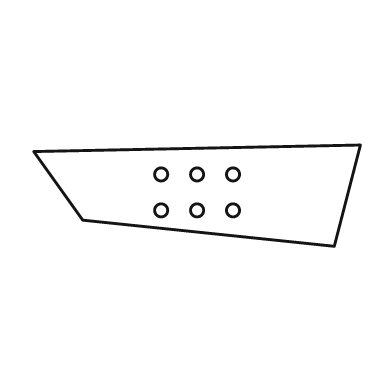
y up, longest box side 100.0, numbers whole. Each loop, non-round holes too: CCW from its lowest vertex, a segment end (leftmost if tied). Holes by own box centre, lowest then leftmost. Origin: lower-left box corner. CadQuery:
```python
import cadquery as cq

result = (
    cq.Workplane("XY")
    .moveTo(92.0, 0.0)
    .lineTo(100.0, 31.0)
    .lineTo(0.0, 29.0)
    .lineTo(15.0, 8.0)
    .close()
    .moveTo(39.0, 11.0)
    .circle(2.0)
    .moveTo(50.0, 11.0)
    .circle(2.0)
    .moveTo(61.0, 11.0)
    .circle(2.0)
    .moveTo(39.0, 22.0)
    .circle(2.0)
    .moveTo(50.0, 22.0)
    .circle(2.0)
    .moveTo(61.0, 22.0)
    .circle(2.0)
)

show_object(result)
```